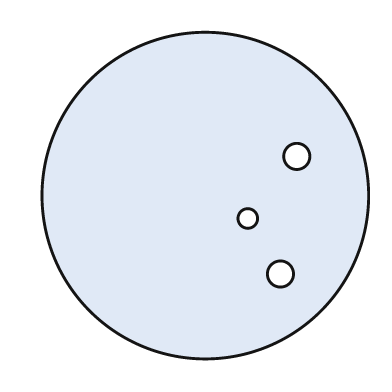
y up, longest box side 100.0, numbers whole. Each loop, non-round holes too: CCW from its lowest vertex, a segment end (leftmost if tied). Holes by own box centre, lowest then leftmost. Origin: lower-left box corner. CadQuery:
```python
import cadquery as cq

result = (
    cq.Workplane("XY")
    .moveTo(50.0, 50.0)
    .circle(50.0)
    .moveTo(73.0, 26.0)
    .circle(4.0)
    .moveTo(63.0, 43.0)
    .circle(3.0)
    .moveTo(78.0, 62.0)
    .circle(4.0)
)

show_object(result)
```